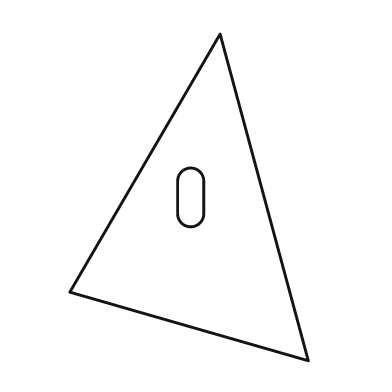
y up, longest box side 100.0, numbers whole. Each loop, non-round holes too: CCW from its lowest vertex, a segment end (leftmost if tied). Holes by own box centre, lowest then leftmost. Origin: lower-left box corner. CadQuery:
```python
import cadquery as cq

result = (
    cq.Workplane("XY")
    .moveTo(73.0, 0.0)
    .lineTo(46.0, 100.0)
    .lineTo(0.0, 21.0)
    .close()
    .moveTo(33.0, 45.0)
    .threePointArc((37.0, 41.0), (41.0, 45.0))
    .lineTo(41.0, 55.0)
    .threePointArc((37.0, 59.0), (33.0, 55.0))
    .close()
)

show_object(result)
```